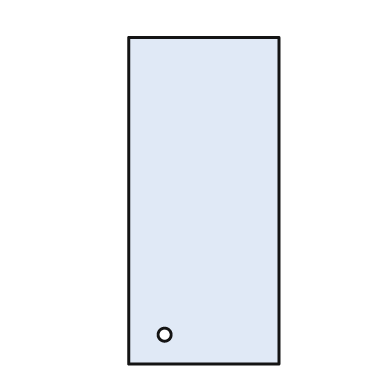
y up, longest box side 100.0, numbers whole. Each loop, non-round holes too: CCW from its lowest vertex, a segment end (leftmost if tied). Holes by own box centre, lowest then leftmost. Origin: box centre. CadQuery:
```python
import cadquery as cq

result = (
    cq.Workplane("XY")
    .moveTo(-23.0, -50.0)
    .lineTo(23.0, -50.0)
    .lineTo(23.0, 50.0)
    .lineTo(-23.0, 50.0)
    .close()
    .moveTo(-12.0, -41.0)
    .circle(2.0)
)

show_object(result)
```